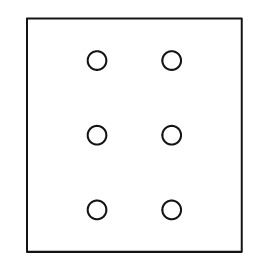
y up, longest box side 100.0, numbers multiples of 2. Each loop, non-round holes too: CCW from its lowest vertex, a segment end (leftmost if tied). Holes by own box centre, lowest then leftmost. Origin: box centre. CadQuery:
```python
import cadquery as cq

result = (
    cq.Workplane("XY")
    .moveTo(-46.0, -50.0)
    .lineTo(46.0, -50.0)
    .lineTo(46.0, 50.0)
    .lineTo(-46.0, 50.0)
    .close()
    .moveTo(-16.0, -32.0)
    .circle(4.0)
    .moveTo(16.0, -32.0)
    .circle(4.0)
    .moveTo(-16.0, 0.0)
    .circle(4.0)
    .moveTo(16.0, 0.0)
    .circle(4.0)
    .moveTo(-16.0, 32.0)
    .circle(4.0)
    .moveTo(16.0, 32.0)
    .circle(4.0)
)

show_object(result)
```